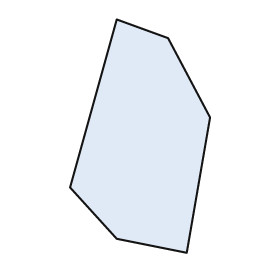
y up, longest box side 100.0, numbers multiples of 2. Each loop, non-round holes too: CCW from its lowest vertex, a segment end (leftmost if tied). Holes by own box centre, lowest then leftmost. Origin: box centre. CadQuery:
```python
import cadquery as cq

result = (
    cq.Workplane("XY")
    .moveTo(20.0, -50.0)
    .lineTo(30.0, 8.0)
    .lineTo(12.0, 42.0)
    .lineTo(-10.0, 50.0)
    .lineTo(-30.0, -22.0)
    .lineTo(-10.0, -44.0)
    .close()
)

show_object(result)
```